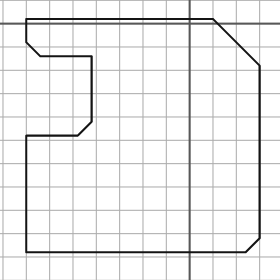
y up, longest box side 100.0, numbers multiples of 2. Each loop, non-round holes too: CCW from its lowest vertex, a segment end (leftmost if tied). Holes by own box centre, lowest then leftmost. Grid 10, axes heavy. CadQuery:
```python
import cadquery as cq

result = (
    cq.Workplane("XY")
    .moveTo(-70.0, -98.0)
    .lineTo(24.0, -98.0)
    .lineTo(30.0, -92.0)
    .lineTo(30.0, -18.0)
    .lineTo(10.0, 2.0)
    .lineTo(-70.0, 2.0)
    .lineTo(-70.0, -8.0)
    .lineTo(-64.0, -14.0)
    .lineTo(-42.0, -14.0)
    .lineTo(-42.0, -42.0)
    .lineTo(-48.0, -48.0)
    .lineTo(-70.0, -48.0)
    .close()
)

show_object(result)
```